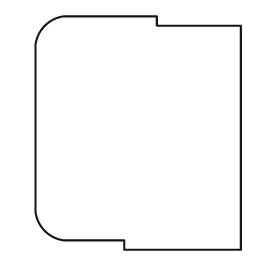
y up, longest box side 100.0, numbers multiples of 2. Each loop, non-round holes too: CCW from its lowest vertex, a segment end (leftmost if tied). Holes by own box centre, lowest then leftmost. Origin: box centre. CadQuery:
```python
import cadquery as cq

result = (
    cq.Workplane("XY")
    .moveTo(-6.0, -50.0)
    .lineTo(44.0, -50.0)
    .lineTo(44.0, 46.0)
    .lineTo(8.0, 46.0)
    .lineTo(8.0, 50.0)
    .lineTo(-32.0, 50.0)
    .threePointArc((-40.0, 46.0), (-44.0, 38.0))
    .lineTo(-44.0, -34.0)
    .threePointArc((-40.0, -42.0), (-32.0, -46.0))
    .lineTo(-6.0, -46.0)
    .close()
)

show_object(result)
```